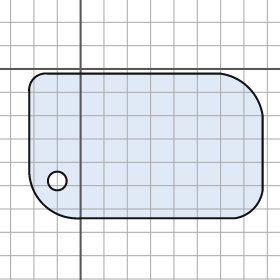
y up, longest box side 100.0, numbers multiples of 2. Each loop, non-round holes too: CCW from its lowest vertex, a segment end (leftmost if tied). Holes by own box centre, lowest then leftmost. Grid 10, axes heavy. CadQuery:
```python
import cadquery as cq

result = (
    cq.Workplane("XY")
    .moveTo(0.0, -64.0)
    .lineTo(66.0, -64.0)
    .threePointArc((74.0, -60.0), (78.0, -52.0))
    .lineTo(78.0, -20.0)
    .threePointArc((72.0, -8.0), (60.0, -2.0))
    .lineTo(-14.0, -2.0)
    .threePointArc((-20.0, -4.0), (-22.0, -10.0))
    .lineTo(-22.0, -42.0)
    .threePointArc((-16.0, -58.0), (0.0, -64.0))
    .close()
    .moveTo(-10.0, -48.0)
    .circle(4.0)
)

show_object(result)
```